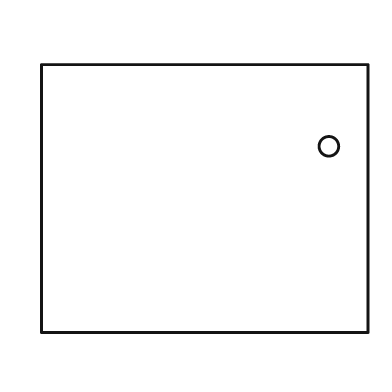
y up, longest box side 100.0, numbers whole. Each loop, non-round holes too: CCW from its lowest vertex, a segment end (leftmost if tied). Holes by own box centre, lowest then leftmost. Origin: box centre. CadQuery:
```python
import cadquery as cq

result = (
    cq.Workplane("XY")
    .moveTo(-50.0, -41.0)
    .lineTo(50.0, -41.0)
    .lineTo(50.0, 41.0)
    .lineTo(-50.0, 41.0)
    .close()
    .moveTo(38.0, 16.0)
    .circle(3.0)
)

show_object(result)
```